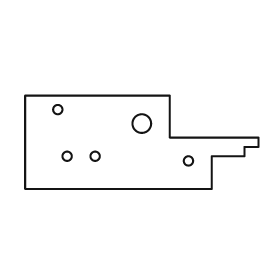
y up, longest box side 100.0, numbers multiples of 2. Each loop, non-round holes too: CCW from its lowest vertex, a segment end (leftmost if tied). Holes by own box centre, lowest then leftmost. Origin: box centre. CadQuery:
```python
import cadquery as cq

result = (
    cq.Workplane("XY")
    .moveTo(-50.0, -20.0)
    .lineTo(30.0, -20.0)
    .lineTo(30.0, -6.0)
    .lineTo(44.0, -6.0)
    .lineTo(44.0, -2.0)
    .lineTo(50.0, -2.0)
    .lineTo(50.0, 2.0)
    .lineTo(12.0, 2.0)
    .lineTo(12.0, 20.0)
    .lineTo(-50.0, 20.0)
    .close()
    .moveTo(20.0, -8.0)
    .circle(2.0)
    .moveTo(-32.0, -6.0)
    .circle(2.0)
    .moveTo(-20.0, -6.0)
    .circle(2.0)
    .moveTo(0.0, 8.0)
    .circle(4.0)
    .moveTo(-36.0, 14.0)
    .circle(2.0)
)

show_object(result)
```